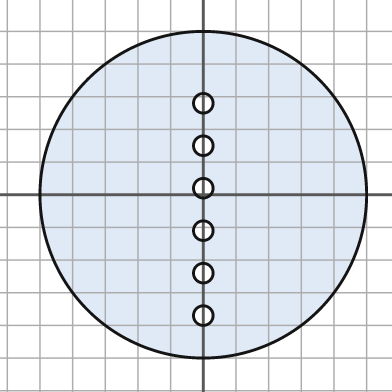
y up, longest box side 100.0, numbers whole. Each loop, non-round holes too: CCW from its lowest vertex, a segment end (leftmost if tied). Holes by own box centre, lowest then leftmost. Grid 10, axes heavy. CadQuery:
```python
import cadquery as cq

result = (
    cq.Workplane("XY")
    .moveTo(0.0, 0.0)
    .circle(50.0)
    .moveTo(0.0, -37.0)
    .circle(3.0)
    .moveTo(0.0, -24.0)
    .circle(3.0)
    .moveTo(0.0, -11.0)
    .circle(3.0)
    .moveTo(0.0, 2.0)
    .circle(3.0)
    .moveTo(0.0, 15.0)
    .circle(3.0)
    .moveTo(0.0, 28.0)
    .circle(3.0)
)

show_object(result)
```